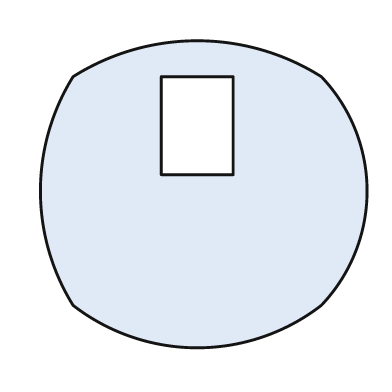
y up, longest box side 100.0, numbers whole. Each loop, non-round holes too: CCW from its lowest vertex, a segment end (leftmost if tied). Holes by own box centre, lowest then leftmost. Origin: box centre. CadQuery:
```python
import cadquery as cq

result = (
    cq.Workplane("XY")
    .moveTo(-40.0, -34.0)
    .threePointArc((-2.0, -47.0), (36.0, -34.0))
    .threePointArc((50.0, 1.0), (36.0, 36.0))
    .threePointArc((-2.0, 47.0), (-40.0, 36.0))
    .threePointArc((-50.0, 1.0), (-40.0, -34.0))
    .close()
    .moveTo(-13.0, 6.0)
    .lineTo(9.0, 6.0)
    .lineTo(9.0, 36.0)
    .lineTo(-13.0, 36.0)
    .close()
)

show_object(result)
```